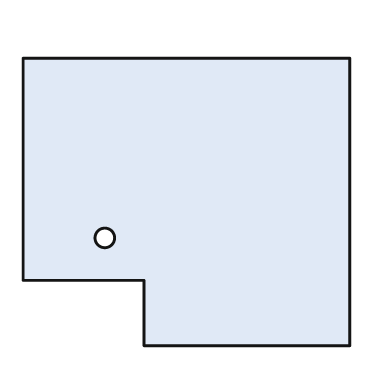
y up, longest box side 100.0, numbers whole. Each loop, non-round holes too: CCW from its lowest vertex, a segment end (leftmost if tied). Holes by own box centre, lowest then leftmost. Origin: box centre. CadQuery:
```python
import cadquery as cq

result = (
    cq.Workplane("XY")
    .moveTo(-13.0, -44.0)
    .lineTo(50.0, -44.0)
    .lineTo(50.0, 44.0)
    .lineTo(-50.0, 44.0)
    .lineTo(-50.0, -24.0)
    .lineTo(-13.0, -24.0)
    .close()
    .moveTo(-25.0, -11.0)
    .circle(3.0)
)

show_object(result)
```